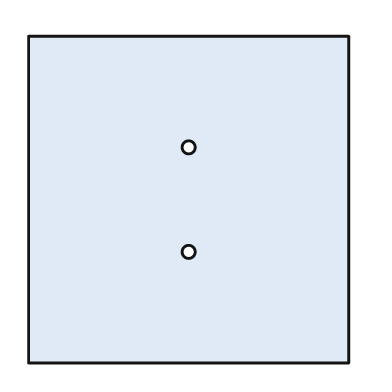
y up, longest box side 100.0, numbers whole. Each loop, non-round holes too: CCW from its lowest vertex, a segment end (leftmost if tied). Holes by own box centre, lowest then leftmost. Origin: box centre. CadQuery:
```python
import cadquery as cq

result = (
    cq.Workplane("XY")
    .moveTo(-49.0, -50.0)
    .lineTo(49.0, -50.0)
    .lineTo(49.0, 50.0)
    .lineTo(-49.0, 50.0)
    .close()
    .moveTo(0.0, -16.0)
    .circle(2.0)
    .moveTo(0.0, 16.0)
    .circle(2.0)
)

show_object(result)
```